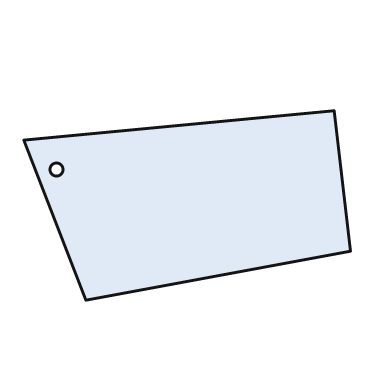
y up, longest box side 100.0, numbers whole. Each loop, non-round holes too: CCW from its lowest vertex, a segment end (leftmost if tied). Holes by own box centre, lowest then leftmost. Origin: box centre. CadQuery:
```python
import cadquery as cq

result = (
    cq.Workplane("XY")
    .moveTo(-31.0, -29.0)
    .lineTo(50.0, -14.0)
    .lineTo(45.0, 29.0)
    .lineTo(-50.0, 20.0)
    .close()
    .moveTo(-40.0, 11.0)
    .circle(2.0)
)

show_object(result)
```